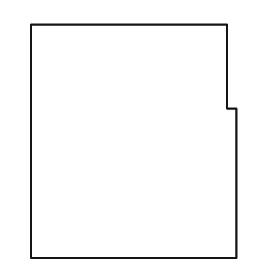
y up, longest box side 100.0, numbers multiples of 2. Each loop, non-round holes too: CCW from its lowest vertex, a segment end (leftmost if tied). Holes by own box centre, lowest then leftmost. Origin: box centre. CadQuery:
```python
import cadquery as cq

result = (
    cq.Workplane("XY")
    .moveTo(-44.0, -50.0)
    .lineTo(44.0, -50.0)
    .lineTo(44.0, 14.0)
    .lineTo(40.0, 14.0)
    .lineTo(40.0, 50.0)
    .lineTo(-44.0, 50.0)
    .close()
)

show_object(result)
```